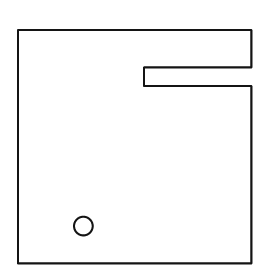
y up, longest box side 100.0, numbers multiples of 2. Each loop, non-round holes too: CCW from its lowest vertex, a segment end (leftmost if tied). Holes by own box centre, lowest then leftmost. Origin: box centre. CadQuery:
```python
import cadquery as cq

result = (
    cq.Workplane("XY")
    .moveTo(-50.0, -50.0)
    .lineTo(50.0, -50.0)
    .lineTo(50.0, 26.0)
    .lineTo(4.0, 26.0)
    .lineTo(4.0, 34.0)
    .lineTo(50.0, 34.0)
    .lineTo(50.0, 50.0)
    .lineTo(-50.0, 50.0)
    .close()
    .moveTo(-22.0, -34.0)
    .circle(4.0)
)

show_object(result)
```